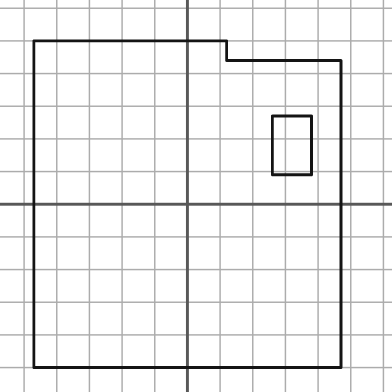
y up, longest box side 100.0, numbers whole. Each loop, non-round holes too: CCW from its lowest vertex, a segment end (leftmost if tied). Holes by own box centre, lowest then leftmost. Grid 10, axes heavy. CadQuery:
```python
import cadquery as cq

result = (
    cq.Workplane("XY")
    .moveTo(-47.0, -50.0)
    .lineTo(47.0, -50.0)
    .lineTo(47.0, 44.0)
    .lineTo(12.0, 44.0)
    .lineTo(12.0, 50.0)
    .lineTo(-47.0, 50.0)
    .close()
    .moveTo(26.0, 9.0)
    .lineTo(38.0, 9.0)
    .lineTo(38.0, 27.0)
    .lineTo(26.0, 27.0)
    .close()
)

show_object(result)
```